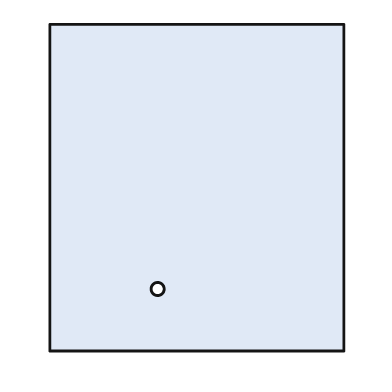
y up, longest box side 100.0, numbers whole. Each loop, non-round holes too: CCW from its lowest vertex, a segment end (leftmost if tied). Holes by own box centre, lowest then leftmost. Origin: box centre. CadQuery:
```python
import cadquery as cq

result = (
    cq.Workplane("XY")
    .moveTo(-45.0, -50.0)
    .lineTo(45.0, -50.0)
    .lineTo(45.0, 50.0)
    .lineTo(-45.0, 50.0)
    .close()
    .moveTo(-12.0, -31.0)
    .circle(2.0)
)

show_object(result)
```